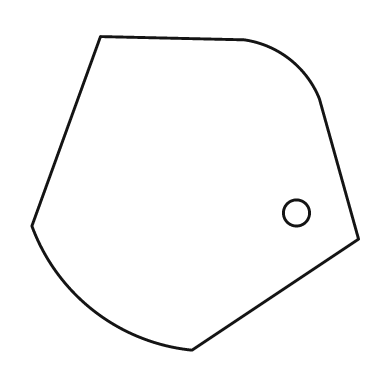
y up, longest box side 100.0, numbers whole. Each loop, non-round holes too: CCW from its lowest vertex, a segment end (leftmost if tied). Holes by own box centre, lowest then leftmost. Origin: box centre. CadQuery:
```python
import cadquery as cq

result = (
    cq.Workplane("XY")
    .moveTo(-1.0, -48.0)
    .lineTo(50.0, -14.0)
    .lineTo(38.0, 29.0)
    .threePointArc((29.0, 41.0), (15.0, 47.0))
    .lineTo(-29.0, 48.0)
    .lineTo(-50.0, -10.0)
    .threePointArc((-31.0, -36.0), (-1.0, -48.0))
    .close()
    .moveTo(31.0, -6.0)
    .circle(4.0)
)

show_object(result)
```